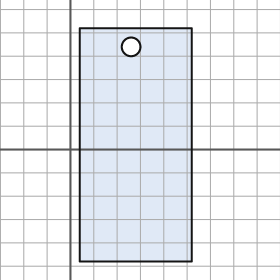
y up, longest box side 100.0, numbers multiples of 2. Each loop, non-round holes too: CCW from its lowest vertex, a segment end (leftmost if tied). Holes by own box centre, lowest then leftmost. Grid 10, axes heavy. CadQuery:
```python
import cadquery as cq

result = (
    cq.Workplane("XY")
    .moveTo(4.0, -48.0)
    .lineTo(52.0, -48.0)
    .lineTo(52.0, 52.0)
    .lineTo(4.0, 52.0)
    .close()
    .moveTo(26.0, 44.0)
    .circle(4.0)
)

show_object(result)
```